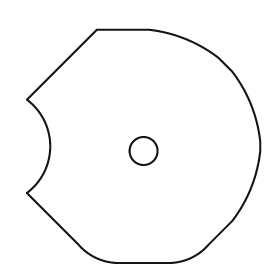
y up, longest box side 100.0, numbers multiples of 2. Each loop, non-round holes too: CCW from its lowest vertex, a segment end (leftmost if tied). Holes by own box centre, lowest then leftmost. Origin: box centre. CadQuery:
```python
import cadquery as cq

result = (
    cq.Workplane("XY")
    .moveTo(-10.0, -50.0)
    .lineTo(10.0, -50.0)
    .threePointArc((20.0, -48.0), (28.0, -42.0))
    .lineTo(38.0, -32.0)
    .threePointArc((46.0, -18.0), (50.0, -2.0))
    .lineTo(50.0, 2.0)
    .threePointArc((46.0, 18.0), (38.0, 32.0))
    .lineTo(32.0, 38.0)
    .threePointArc((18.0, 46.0), (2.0, 50.0))
    .lineTo(-20.0, 50.0)
    .lineTo(-50.0, 20.0)
    .threePointArc((-40.0, 0.0), (-50.0, -20.0))
    .lineTo(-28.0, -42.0)
    .threePointArc((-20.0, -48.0), (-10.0, -50.0))
    .close()
    .moveTo(0.0, -2.0)
    .circle(6.0)
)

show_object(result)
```